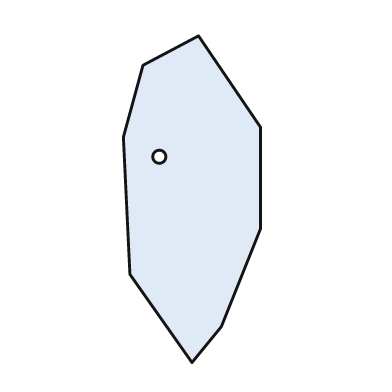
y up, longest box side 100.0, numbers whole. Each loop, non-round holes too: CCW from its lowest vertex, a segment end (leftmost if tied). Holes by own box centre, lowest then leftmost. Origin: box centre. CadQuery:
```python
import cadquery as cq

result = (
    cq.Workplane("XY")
    .moveTo(0.0, -50.0)
    .lineTo(9.0, -39.0)
    .lineTo(21.0, -9.0)
    .lineTo(21.0, 22.0)
    .lineTo(2.0, 50.0)
    .lineTo(-15.0, 41.0)
    .lineTo(-21.0, 19.0)
    .lineTo(-19.0, -23.0)
    .close()
    .moveTo(-10.0, 13.0)
    .circle(2.0)
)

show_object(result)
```